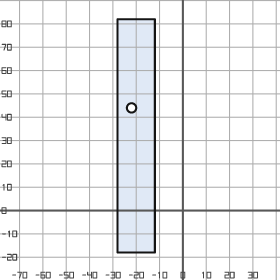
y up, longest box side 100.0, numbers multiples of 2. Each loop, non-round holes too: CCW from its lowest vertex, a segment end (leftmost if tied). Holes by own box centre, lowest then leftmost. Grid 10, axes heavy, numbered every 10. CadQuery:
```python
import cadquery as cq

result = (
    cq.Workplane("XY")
    .moveTo(-28.0, -18.0)
    .lineTo(-12.0, -18.0)
    .lineTo(-12.0, 82.0)
    .lineTo(-28.0, 82.0)
    .close()
    .moveTo(-22.0, 44.0)
    .circle(2.0)
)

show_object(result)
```